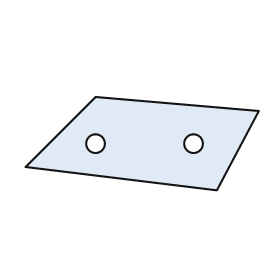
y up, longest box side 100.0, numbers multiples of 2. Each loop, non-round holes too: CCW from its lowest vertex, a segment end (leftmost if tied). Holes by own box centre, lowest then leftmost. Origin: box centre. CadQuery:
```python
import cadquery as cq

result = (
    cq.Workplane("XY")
    .moveTo(32.0, -20.0)
    .lineTo(50.0, 14.0)
    .lineTo(-20.0, 20.0)
    .lineTo(-50.0, -10.0)
    .close()
    .moveTo(-20.0, 0.0)
    .circle(4.0)
    .moveTo(22.0, 0.0)
    .circle(4.0)
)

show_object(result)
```